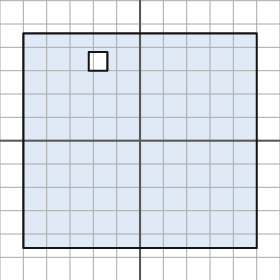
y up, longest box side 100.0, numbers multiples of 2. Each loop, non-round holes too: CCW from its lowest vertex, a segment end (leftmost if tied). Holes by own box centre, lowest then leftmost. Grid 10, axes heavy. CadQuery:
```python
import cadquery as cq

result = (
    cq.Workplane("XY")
    .moveTo(-50.0, -46.0)
    .lineTo(50.0, -46.0)
    .lineTo(50.0, 46.0)
    .lineTo(-50.0, 46.0)
    .close()
    .moveTo(-22.0, 30.0)
    .lineTo(-14.0, 30.0)
    .lineTo(-14.0, 38.0)
    .lineTo(-22.0, 38.0)
    .close()
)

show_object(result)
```